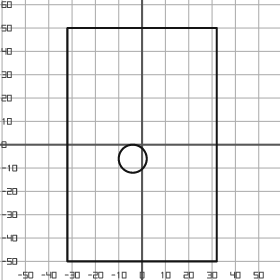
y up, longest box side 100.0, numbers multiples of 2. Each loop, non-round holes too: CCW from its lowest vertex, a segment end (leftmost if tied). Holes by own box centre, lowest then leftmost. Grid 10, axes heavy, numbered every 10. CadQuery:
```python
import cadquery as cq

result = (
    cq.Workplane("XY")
    .moveTo(-32.0, -50.0)
    .lineTo(32.0, -50.0)
    .lineTo(32.0, 50.0)
    .lineTo(-32.0, 50.0)
    .close()
    .moveTo(-4.0, -6.0)
    .circle(6.0)
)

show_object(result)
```